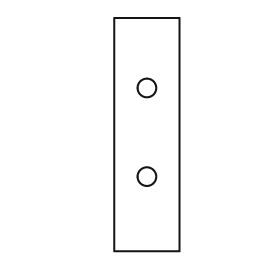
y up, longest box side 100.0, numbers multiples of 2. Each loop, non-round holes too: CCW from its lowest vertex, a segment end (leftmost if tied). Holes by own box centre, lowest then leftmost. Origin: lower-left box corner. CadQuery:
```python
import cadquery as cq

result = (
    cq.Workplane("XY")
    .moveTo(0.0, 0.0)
    .lineTo(28.0, 0.0)
    .lineTo(28.0, 100.0)
    .lineTo(0.0, 100.0)
    .close()
    .moveTo(14.0, 32.0)
    .circle(4.0)
    .moveTo(14.0, 70.0)
    .circle(4.0)
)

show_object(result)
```